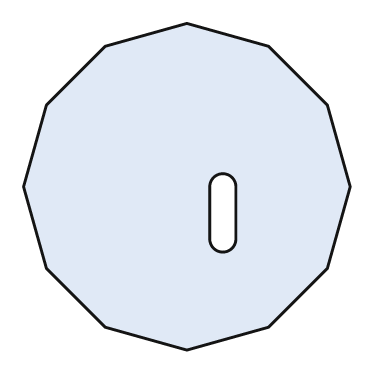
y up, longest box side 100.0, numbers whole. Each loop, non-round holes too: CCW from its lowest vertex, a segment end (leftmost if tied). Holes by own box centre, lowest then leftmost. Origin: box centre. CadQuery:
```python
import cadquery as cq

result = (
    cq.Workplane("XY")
    .moveTo(0.0, -50.0)
    .lineTo(25.0, -43.0)
    .lineTo(43.0, -25.0)
    .lineTo(50.0, 0.0)
    .lineTo(43.0, 25.0)
    .lineTo(25.0, 43.0)
    .lineTo(0.0, 50.0)
    .lineTo(-25.0, 43.0)
    .lineTo(-43.0, 25.0)
    .lineTo(-50.0, 0.0)
    .lineTo(-43.0, -25.0)
    .lineTo(-25.0, -43.0)
    .close()
    .moveTo(7.0, -16.0)
    .threePointArc((11.0, -20.0), (15.0, -16.0))
    .lineTo(15.0, 0.0)
    .threePointArc((11.0, 4.0), (7.0, 0.0))
    .close()
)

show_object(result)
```